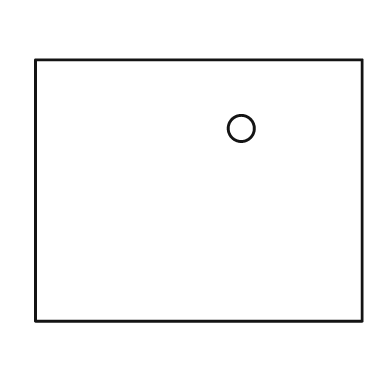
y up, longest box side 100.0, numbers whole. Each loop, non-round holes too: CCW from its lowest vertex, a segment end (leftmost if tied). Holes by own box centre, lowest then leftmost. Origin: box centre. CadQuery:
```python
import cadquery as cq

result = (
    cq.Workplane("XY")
    .moveTo(-50.0, -40.0)
    .lineTo(50.0, -40.0)
    .lineTo(50.0, 40.0)
    .lineTo(-50.0, 40.0)
    .close()
    .moveTo(13.0, 19.0)
    .circle(4.0)
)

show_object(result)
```